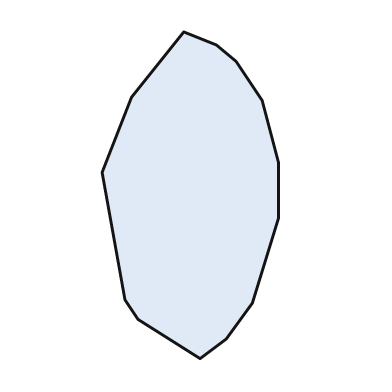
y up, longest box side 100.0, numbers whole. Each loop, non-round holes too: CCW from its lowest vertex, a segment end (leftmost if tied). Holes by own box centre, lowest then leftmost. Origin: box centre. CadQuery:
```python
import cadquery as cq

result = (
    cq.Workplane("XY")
    .moveTo(3.0, -50.0)
    .lineTo(11.0, -44.0)
    .lineTo(19.0, -33.0)
    .lineTo(27.0, -7.0)
    .lineTo(27.0, 10.0)
    .lineTo(22.0, 29.0)
    .lineTo(14.0, 41.0)
    .lineTo(8.0, 46.0)
    .lineTo(-2.0, 50.0)
    .lineTo(-18.0, 30.0)
    .lineTo(-27.0, 7.0)
    .lineTo(-20.0, -32.0)
    .lineTo(-16.0, -38.0)
    .close()
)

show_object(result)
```